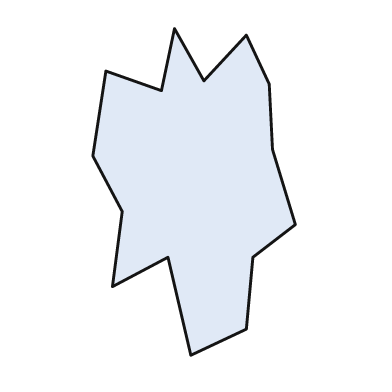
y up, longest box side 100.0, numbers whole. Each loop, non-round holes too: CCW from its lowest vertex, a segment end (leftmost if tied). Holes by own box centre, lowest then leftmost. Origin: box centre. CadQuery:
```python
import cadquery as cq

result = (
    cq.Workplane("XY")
    .moveTo(-1.0, -50.0)
    .lineTo(16.0, -42.0)
    .lineTo(18.0, -20.0)
    .lineTo(31.0, -10.0)
    .lineTo(24.0, 13.0)
    .lineTo(23.0, 33.0)
    .lineTo(16.0, 48.0)
    .lineTo(3.0, 34.0)
    .lineTo(-6.0, 50.0)
    .lineTo(-10.0, 31.0)
    .lineTo(-27.0, 37.0)
    .lineTo(-31.0, 11.0)
    .lineTo(-22.0, -6.0)
    .lineTo(-25.0, -29.0)
    .lineTo(-8.0, -20.0)
    .close()
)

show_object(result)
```